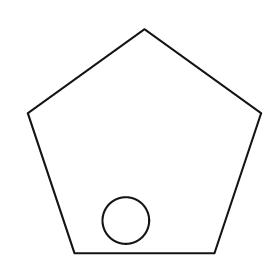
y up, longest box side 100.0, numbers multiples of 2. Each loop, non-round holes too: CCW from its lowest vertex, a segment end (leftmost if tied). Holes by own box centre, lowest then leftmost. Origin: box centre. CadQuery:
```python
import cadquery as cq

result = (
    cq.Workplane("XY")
    .moveTo(-30.0, -48.0)
    .lineTo(30.0, -48.0)
    .lineTo(50.0, 12.0)
    .lineTo(0.0, 48.0)
    .lineTo(-50.0, 12.0)
    .close()
    .moveTo(-8.0, -34.0)
    .circle(10.0)
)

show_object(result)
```